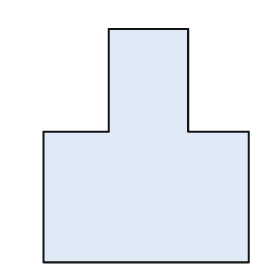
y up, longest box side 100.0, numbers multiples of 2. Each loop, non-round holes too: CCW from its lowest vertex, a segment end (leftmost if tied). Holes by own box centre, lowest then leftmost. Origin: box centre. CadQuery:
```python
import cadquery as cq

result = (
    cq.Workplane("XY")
    .moveTo(-44.0, -50.0)
    .lineTo(44.0, -50.0)
    .lineTo(44.0, 6.0)
    .lineTo(18.0, 6.0)
    .lineTo(18.0, 50.0)
    .lineTo(-16.0, 50.0)
    .lineTo(-16.0, 6.0)
    .lineTo(-44.0, 6.0)
    .close()
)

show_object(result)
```